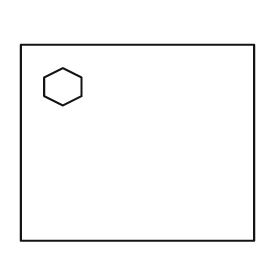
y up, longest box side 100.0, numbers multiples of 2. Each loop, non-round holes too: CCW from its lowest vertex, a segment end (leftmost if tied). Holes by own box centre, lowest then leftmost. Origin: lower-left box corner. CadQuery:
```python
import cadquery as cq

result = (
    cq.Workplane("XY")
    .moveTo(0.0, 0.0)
    .lineTo(100.0, 0.0)
    .lineTo(100.0, 84.0)
    .lineTo(0.0, 84.0)
    .close()
    .moveTo(18.0, 58.0)
    .lineTo(26.0, 62.0)
    .lineTo(26.0, 70.0)
    .lineTo(18.0, 74.0)
    .lineTo(10.0, 70.0)
    .lineTo(10.0, 62.0)
    .close()
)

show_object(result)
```